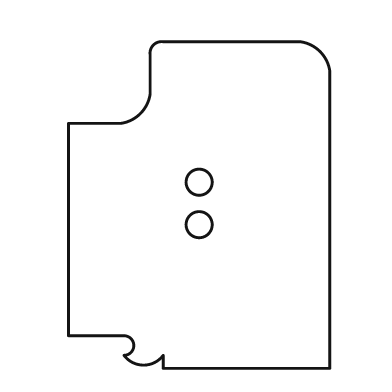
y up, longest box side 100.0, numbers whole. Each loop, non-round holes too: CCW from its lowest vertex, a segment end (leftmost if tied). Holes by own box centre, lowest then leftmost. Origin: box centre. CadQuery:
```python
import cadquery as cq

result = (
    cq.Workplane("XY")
    .moveTo(-11.0, -50.0)
    .lineTo(40.0, -50.0)
    .lineTo(40.0, 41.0)
    .threePointArc((37.0, 47.0), (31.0, 50.0))
    .lineTo(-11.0, 50.0)
    .threePointArc((-14.0, 49.0), (-15.0, 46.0))
    .lineTo(-15.0, 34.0)
    .threePointArc((-18.0, 28.0), (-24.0, 25.0))
    .lineTo(-40.0, 25.0)
    .lineTo(-40.0, -40.0)
    .lineTo(-23.0, -40.0)
    .threePointArc((-20.0, -43.0), (-23.0, -46.0))
    .threePointArc((-17.0, -49.0), (-11.0, -46.0))
    .close()
    .moveTo(0.0, -6.0)
    .circle(4.0)
    .moveTo(0.0, 7.0)
    .circle(4.0)
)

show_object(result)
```